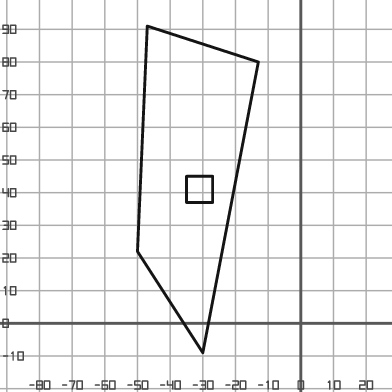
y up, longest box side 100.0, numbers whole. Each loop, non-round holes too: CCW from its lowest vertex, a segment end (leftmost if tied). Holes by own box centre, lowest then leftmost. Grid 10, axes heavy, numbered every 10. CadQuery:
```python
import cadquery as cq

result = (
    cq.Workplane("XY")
    .moveTo(-30.0, -9.0)
    .lineTo(-13.0, 80.0)
    .lineTo(-47.0, 91.0)
    .lineTo(-50.0, 22.0)
    .close()
    .moveTo(-35.0, 37.0)
    .lineTo(-27.0, 37.0)
    .lineTo(-27.0, 45.0)
    .lineTo(-35.0, 45.0)
    .close()
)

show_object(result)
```